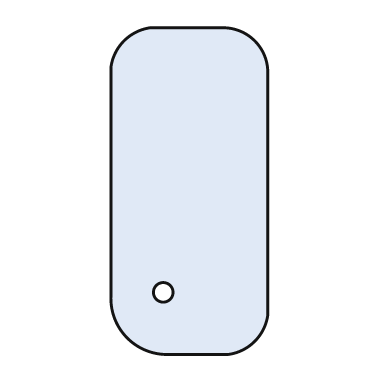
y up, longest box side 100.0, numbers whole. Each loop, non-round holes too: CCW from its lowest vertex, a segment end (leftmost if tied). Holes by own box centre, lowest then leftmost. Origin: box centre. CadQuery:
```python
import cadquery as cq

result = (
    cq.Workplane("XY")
    .moveTo(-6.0, -50.0)
    .lineTo(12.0, -50.0)
    .threePointArc((20.0, -46.0), (24.0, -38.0))
    .lineTo(24.0, 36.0)
    .threePointArc((20.0, 46.0), (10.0, 50.0))
    .lineTo(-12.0, 50.0)
    .threePointArc((-20.0, 46.0), (-24.0, 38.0))
    .lineTo(-24.0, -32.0)
    .threePointArc((-19.0, -45.0), (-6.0, -50.0))
    .close()
    .moveTo(-8.0, -31.0)
    .circle(3.0)
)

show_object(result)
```